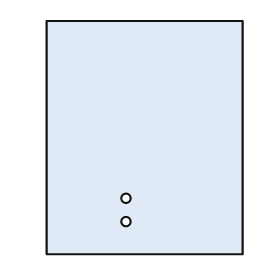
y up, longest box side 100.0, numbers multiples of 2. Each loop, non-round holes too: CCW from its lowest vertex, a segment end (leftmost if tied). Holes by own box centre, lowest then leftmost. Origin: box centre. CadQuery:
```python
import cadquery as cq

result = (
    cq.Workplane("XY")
    .moveTo(-42.0, -50.0)
    .lineTo(42.0, -50.0)
    .lineTo(42.0, 50.0)
    .lineTo(-42.0, 50.0)
    .close()
    .moveTo(-8.0, -36.0)
    .circle(2.0)
    .moveTo(-8.0, -26.0)
    .circle(2.0)
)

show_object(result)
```